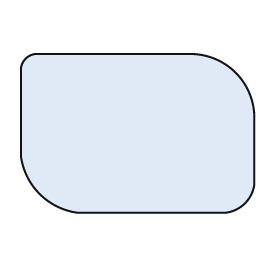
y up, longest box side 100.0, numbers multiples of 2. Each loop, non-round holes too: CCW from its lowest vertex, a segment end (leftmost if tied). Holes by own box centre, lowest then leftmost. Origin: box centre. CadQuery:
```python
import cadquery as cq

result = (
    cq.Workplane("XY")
    .moveTo(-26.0, -34.0)
    .lineTo(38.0, -34.0)
    .threePointArc((46.0, -30.0), (50.0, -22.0))
    .lineTo(50.0, 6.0)
    .threePointArc((42.0, 26.0), (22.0, 34.0))
    .lineTo(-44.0, 34.0)
    .threePointArc((-48.0, 32.0), (-50.0, 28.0))
    .lineTo(-50.0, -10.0)
    .threePointArc((-42.0, -26.0), (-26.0, -34.0))
    .close()
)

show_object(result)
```